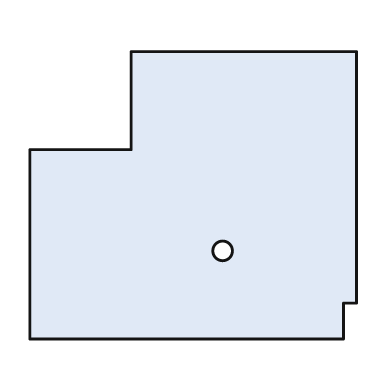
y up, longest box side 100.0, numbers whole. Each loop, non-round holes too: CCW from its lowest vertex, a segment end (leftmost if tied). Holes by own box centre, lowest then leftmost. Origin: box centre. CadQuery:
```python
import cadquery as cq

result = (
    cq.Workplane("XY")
    .moveTo(-50.0, -44.0)
    .lineTo(46.0, -44.0)
    .lineTo(46.0, -33.0)
    .lineTo(50.0, -33.0)
    .lineTo(50.0, 44.0)
    .lineTo(-19.0, 44.0)
    .lineTo(-19.0, 14.0)
    .lineTo(-50.0, 14.0)
    .close()
    .moveTo(9.0, -17.0)
    .circle(3.0)
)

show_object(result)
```